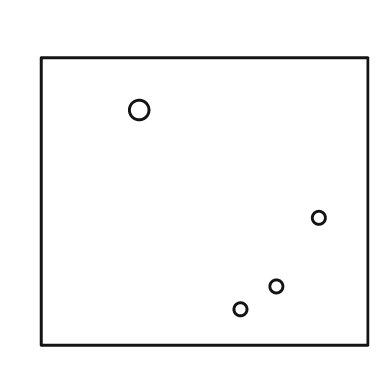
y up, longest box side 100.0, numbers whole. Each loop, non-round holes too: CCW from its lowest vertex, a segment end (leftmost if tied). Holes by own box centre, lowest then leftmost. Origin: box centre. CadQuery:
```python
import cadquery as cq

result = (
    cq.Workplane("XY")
    .moveTo(-50.0, -44.0)
    .lineTo(50.0, -44.0)
    .lineTo(50.0, 44.0)
    .lineTo(-50.0, 44.0)
    .close()
    .moveTo(11.0, -33.0)
    .circle(2.0)
    .moveTo(22.0, -26.0)
    .circle(2.0)
    .moveTo(35.0, -5.0)
    .circle(2.0)
    .moveTo(-20.0, 28.0)
    .circle(3.0)
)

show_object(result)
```